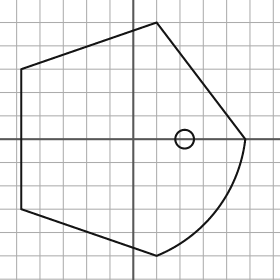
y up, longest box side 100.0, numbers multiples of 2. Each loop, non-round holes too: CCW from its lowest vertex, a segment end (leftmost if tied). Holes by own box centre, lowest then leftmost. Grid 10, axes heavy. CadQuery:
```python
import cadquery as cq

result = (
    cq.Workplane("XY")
    .moveTo(10.0, -50.0)
    .threePointArc((36.0, -30.0), (48.0, 0.0))
    .lineTo(10.0, 50.0)
    .lineTo(-48.0, 30.0)
    .lineTo(-48.0, -30.0)
    .close()
    .moveTo(22.0, 0.0)
    .circle(4.0)
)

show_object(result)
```